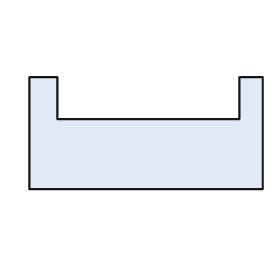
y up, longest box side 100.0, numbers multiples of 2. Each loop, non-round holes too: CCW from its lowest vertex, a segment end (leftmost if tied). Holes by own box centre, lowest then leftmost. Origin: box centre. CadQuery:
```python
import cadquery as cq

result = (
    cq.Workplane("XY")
    .moveTo(-50.0, -24.0)
    .lineTo(50.0, -24.0)
    .lineTo(50.0, 24.0)
    .lineTo(40.0, 24.0)
    .lineTo(40.0, 6.0)
    .lineTo(-38.0, 6.0)
    .lineTo(-38.0, 24.0)
    .lineTo(-50.0, 24.0)
    .close()
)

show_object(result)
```